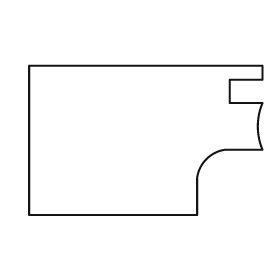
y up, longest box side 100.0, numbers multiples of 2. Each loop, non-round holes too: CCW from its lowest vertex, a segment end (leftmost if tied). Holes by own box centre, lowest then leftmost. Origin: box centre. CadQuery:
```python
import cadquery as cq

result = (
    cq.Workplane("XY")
    .moveTo(-50.0, -32.0)
    .lineTo(22.0, -32.0)
    .lineTo(22.0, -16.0)
    .threePointArc((26.0, -8.0), (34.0, -4.0))
    .lineTo(50.0, -4.0)
    .threePointArc((48.0, 6.0), (50.0, 16.0))
    .lineTo(36.0, 16.0)
    .lineTo(36.0, 26.0)
    .lineTo(50.0, 26.0)
    .lineTo(50.0, 32.0)
    .lineTo(-50.0, 32.0)
    .close()
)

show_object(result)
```